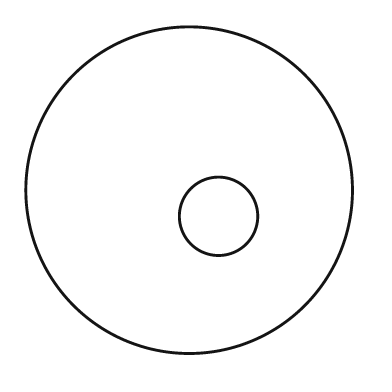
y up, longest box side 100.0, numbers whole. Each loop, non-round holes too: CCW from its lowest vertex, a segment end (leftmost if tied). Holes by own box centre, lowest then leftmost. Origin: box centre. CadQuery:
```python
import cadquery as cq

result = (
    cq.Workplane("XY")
    .moveTo(0.0, 0.0)
    .circle(50.0)
    .moveTo(9.0, -8.0)
    .circle(12.0)
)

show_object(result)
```